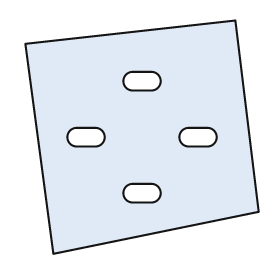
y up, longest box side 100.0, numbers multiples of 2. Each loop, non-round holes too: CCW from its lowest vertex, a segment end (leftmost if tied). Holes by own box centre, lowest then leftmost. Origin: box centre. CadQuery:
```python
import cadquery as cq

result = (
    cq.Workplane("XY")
    .moveTo(-38.0, -50.0)
    .lineTo(50.0, -32.0)
    .lineTo(40.0, 50.0)
    .lineTo(-50.0, 40.0)
    .close()
    .moveTo(-4.0, -28.0)
    .lineTo(4.0, -28.0)
    .threePointArc((8.0, -24.0), (4.0, -20.0))
    .lineTo(-4.0, -20.0)
    .threePointArc((-8.0, -24.0), (-4.0, -28.0))
    .close()
    .moveTo(-28.0, -4.0)
    .lineTo(-20.0, -4.0)
    .threePointArc((-16.0, 0.0), (-20.0, 4.0))
    .lineTo(-28.0, 4.0)
    .threePointArc((-32.0, 0.0), (-28.0, -4.0))
    .close()
    .moveTo(20.0, -4.0)
    .lineTo(28.0, -4.0)
    .threePointArc((32.0, 0.0), (28.0, 4.0))
    .lineTo(20.0, 4.0)
    .threePointArc((16.0, 0.0), (20.0, -4.0))
    .close()
    .moveTo(-4.0, 20.0)
    .lineTo(4.0, 20.0)
    .threePointArc((8.0, 24.0), (4.0, 28.0))
    .lineTo(-4.0, 28.0)
    .threePointArc((-8.0, 24.0), (-4.0, 20.0))
    .close()
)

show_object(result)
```